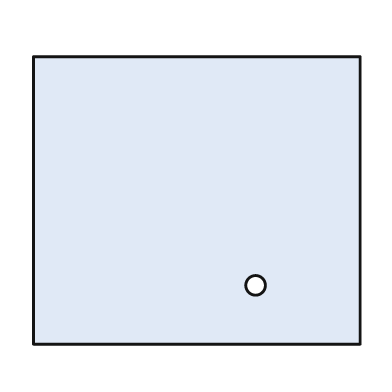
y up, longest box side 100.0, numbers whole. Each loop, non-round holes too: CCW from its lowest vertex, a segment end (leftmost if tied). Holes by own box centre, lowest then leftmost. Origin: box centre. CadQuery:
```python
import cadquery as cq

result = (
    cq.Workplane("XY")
    .moveTo(-50.0, -44.0)
    .lineTo(50.0, -44.0)
    .lineTo(50.0, 44.0)
    .lineTo(-50.0, 44.0)
    .close()
    .moveTo(18.0, -26.0)
    .circle(3.0)
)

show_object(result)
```